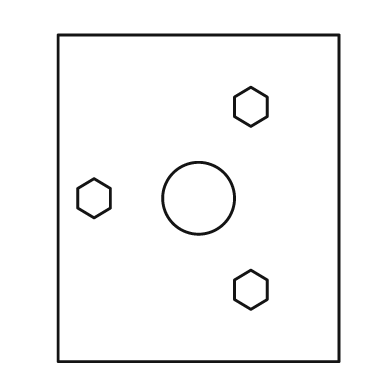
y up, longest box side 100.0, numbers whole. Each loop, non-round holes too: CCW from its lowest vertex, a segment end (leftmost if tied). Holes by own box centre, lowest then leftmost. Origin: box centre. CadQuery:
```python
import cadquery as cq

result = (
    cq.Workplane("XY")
    .moveTo(-43.0, -50.0)
    .lineTo(43.0, -50.0)
    .lineTo(43.0, 50.0)
    .lineTo(-43.0, 50.0)
    .close()
    .moveTo(16.0, -34.0)
    .lineTo(21.0, -31.0)
    .lineTo(21.0, -25.0)
    .lineTo(16.0, -22.0)
    .lineTo(11.0, -25.0)
    .lineTo(11.0, -31.0)
    .close()
    .moveTo(-32.0, -6.0)
    .lineTo(-27.0, -3.0)
    .lineTo(-27.0, 3.0)
    .lineTo(-32.0, 6.0)
    .lineTo(-37.0, 3.0)
    .lineTo(-37.0, -3.0)
    .close()
    .moveTo(0.0, 0.0)
    .circle(11.0)
    .moveTo(16.0, 22.0)
    .lineTo(21.0, 25.0)
    .lineTo(21.0, 31.0)
    .lineTo(16.0, 34.0)
    .lineTo(11.0, 31.0)
    .lineTo(11.0, 25.0)
    .close()
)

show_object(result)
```